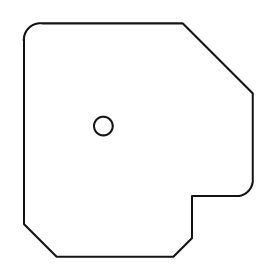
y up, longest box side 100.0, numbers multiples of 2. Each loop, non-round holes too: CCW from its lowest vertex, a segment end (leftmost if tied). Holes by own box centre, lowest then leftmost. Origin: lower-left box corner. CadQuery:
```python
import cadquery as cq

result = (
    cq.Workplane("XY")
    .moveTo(14.0, 0.0)
    .lineTo(64.0, 0.0)
    .lineTo(72.0, 8.0)
    .lineTo(72.0, 26.0)
    .lineTo(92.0, 26.0)
    .threePointArc((96.0, 28.0), (98.0, 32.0))
    .lineTo(98.0, 70.0)
    .lineTo(68.0, 100.0)
    .lineTo(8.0, 100.0)
    .threePointArc((2.0, 98.0), (0.0, 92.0))
    .lineTo(0.0, 14.0)
    .close()
    .moveTo(34.0, 56.0)
    .circle(4.0)
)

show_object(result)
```